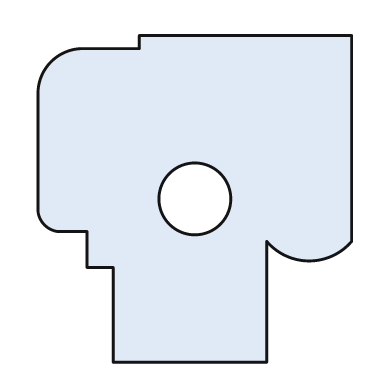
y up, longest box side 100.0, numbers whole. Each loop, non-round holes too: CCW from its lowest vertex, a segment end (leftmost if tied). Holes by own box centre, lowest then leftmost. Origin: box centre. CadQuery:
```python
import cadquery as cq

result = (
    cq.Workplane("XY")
    .moveTo(-25.0, -50.0)
    .lineTo(22.0, -50.0)
    .lineTo(22.0, -13.0)
    .threePointArc((35.0, -19.0), (48.0, -13.0))
    .lineTo(48.0, 50.0)
    .lineTo(-17.0, 50.0)
    .lineTo(-17.0, 46.0)
    .lineTo(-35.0, 46.0)
    .threePointArc((-44.0, 42.0), (-48.0, 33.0))
    .lineTo(-48.0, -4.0)
    .threePointArc((-46.0, -8.0), (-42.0, -10.0))
    .lineTo(-33.0, -10.0)
    .lineTo(-33.0, -21.0)
    .lineTo(-25.0, -21.0)
    .close()
    .moveTo(0.0, 0.0)
    .circle(11.0)
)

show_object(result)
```